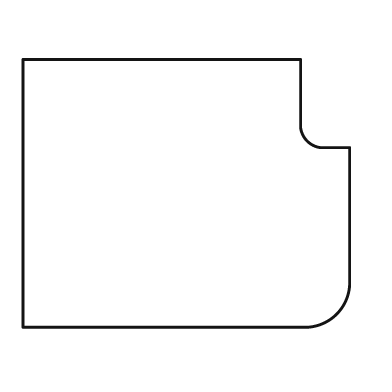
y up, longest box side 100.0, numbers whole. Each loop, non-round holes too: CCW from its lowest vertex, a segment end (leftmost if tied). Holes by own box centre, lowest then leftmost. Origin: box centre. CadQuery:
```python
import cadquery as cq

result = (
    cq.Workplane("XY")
    .moveTo(-50.0, -41.0)
    .lineTo(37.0, -41.0)
    .threePointArc((46.0, -37.0), (50.0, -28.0))
    .lineTo(50.0, 14.0)
    .lineTo(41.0, 14.0)
    .threePointArc((37.0, 16.0), (35.0, 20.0))
    .lineTo(35.0, 41.0)
    .lineTo(-50.0, 41.0)
    .close()
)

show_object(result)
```